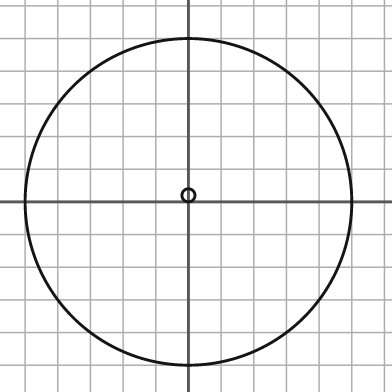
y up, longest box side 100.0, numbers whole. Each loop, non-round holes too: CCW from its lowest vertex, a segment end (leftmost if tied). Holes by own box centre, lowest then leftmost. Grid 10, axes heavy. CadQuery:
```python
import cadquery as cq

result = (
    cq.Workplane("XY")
    .moveTo(0.0, 0.0)
    .circle(50.0)
    .moveTo(0.0, 2.0)
    .circle(2.0)
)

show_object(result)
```